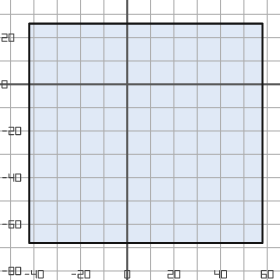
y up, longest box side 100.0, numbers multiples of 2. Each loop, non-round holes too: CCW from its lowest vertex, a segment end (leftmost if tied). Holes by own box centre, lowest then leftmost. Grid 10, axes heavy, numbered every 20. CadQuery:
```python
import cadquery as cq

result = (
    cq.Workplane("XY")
    .moveTo(-42.0, -68.0)
    .lineTo(58.0, -68.0)
    .lineTo(58.0, 26.0)
    .lineTo(-42.0, 26.0)
    .close()
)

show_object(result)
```